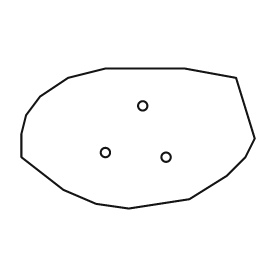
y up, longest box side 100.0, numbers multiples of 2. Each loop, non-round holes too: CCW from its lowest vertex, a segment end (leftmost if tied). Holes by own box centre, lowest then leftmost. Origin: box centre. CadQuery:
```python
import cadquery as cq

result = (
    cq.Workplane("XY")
    .moveTo(-4.0, -30.0)
    .lineTo(22.0, -26.0)
    .lineTo(38.0, -16.0)
    .lineTo(46.0, -8.0)
    .lineTo(50.0, 0.0)
    .lineTo(42.0, 26.0)
    .lineTo(20.0, 30.0)
    .lineTo(-14.0, 30.0)
    .lineTo(-30.0, 26.0)
    .lineTo(-42.0, 18.0)
    .lineTo(-48.0, 10.0)
    .lineTo(-50.0, 2.0)
    .lineTo(-50.0, -8.0)
    .lineTo(-32.0, -22.0)
    .lineTo(-18.0, -28.0)
    .close()
    .moveTo(12.0, -8.0)
    .circle(2.0)
    .moveTo(-14.0, -6.0)
    .circle(2.0)
    .moveTo(2.0, 14.0)
    .circle(2.0)
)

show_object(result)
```